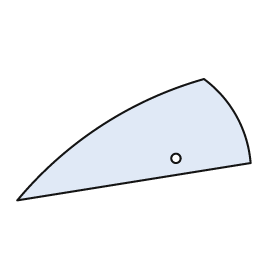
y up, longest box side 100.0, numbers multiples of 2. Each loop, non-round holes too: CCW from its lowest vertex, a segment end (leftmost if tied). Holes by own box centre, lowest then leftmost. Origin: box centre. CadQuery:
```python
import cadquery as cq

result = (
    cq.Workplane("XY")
    .moveTo(-50.0, -26.0)
    .lineTo(50.0, -10.0)
    .threePointArc((44.0, 10.0), (30.0, 26.0))
    .threePointArc((-14.0, 6.0), (-50.0, -26.0))
    .close()
    .moveTo(18.0, -8.0)
    .circle(2.0)
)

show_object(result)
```